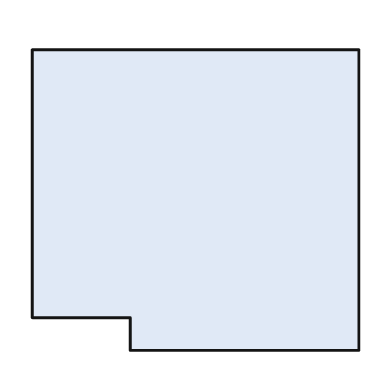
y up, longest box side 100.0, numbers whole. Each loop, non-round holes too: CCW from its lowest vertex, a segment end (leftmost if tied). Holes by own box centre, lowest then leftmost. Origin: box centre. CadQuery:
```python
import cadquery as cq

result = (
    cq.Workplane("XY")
    .moveTo(-20.0, -46.0)
    .lineTo(50.0, -46.0)
    .lineTo(50.0, 46.0)
    .lineTo(-50.0, 46.0)
    .lineTo(-50.0, -36.0)
    .lineTo(-20.0, -36.0)
    .close()
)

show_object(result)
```